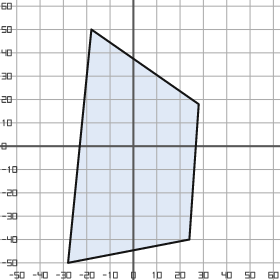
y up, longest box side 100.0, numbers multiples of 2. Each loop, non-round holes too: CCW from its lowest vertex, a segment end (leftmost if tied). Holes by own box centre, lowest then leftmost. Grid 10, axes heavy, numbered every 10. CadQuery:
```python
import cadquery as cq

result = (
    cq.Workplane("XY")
    .moveTo(-28.0, -50.0)
    .lineTo(24.0, -40.0)
    .lineTo(28.0, 18.0)
    .lineTo(-18.0, 50.0)
    .close()
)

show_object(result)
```